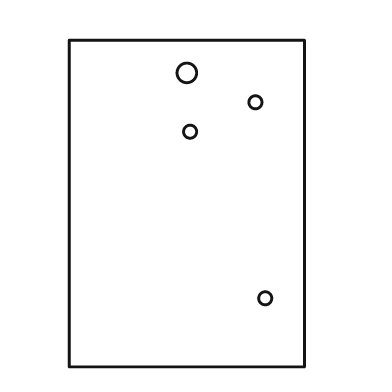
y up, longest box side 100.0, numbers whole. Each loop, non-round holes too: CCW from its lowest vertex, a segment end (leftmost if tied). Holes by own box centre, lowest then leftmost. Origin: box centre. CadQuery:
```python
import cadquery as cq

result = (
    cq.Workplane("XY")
    .moveTo(-36.0, -50.0)
    .lineTo(36.0, -50.0)
    .lineTo(36.0, 50.0)
    .lineTo(-36.0, 50.0)
    .close()
    .moveTo(24.0, -29.0)
    .circle(2.0)
    .moveTo(1.0, 22.0)
    .circle(2.0)
    .moveTo(21.0, 31.0)
    .circle(2.0)
    .moveTo(0.0, 40.0)
    .circle(3.0)
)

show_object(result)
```